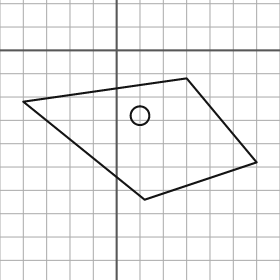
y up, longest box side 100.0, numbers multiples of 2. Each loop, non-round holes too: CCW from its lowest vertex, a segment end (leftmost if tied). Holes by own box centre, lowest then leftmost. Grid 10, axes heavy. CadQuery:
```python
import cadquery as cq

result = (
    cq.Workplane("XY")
    .moveTo(12.0, -64.0)
    .lineTo(60.0, -48.0)
    .lineTo(30.0, -12.0)
    .lineTo(-40.0, -22.0)
    .close()
    .moveTo(10.0, -28.0)
    .circle(4.0)
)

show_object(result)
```